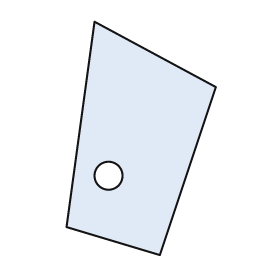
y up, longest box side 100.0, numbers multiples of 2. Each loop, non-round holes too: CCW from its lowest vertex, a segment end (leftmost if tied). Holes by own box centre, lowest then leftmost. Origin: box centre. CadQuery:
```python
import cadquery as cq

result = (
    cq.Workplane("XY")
    .moveTo(8.0, -50.0)
    .lineTo(32.0, 22.0)
    .lineTo(-20.0, 50.0)
    .lineTo(-32.0, -38.0)
    .close()
    .moveTo(-14.0, -16.0)
    .circle(6.0)
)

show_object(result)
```